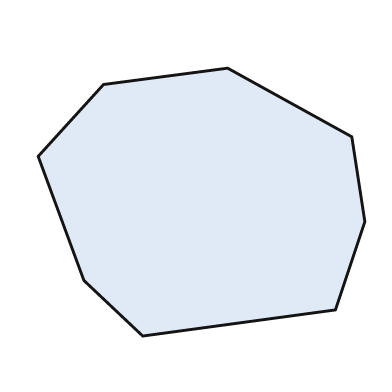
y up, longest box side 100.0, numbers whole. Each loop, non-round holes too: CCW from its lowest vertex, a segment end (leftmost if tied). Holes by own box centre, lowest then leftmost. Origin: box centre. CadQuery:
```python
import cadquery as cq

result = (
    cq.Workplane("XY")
    .moveTo(-18.0, -41.0)
    .lineTo(41.0, -33.0)
    .lineTo(50.0, -6.0)
    .lineTo(46.0, 20.0)
    .lineTo(8.0, 41.0)
    .lineTo(-30.0, 36.0)
    .lineTo(-50.0, 14.0)
    .lineTo(-36.0, -24.0)
    .close()
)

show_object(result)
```